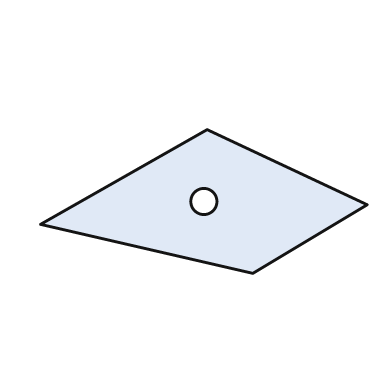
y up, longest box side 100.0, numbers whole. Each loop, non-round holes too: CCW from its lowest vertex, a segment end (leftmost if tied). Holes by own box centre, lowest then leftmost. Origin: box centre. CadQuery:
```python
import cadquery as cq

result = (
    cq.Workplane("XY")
    .moveTo(15.0, -22.0)
    .lineTo(50.0, -1.0)
    .lineTo(1.0, 22.0)
    .lineTo(-50.0, -7.0)
    .close()
    .moveTo(0.0, 0.0)
    .circle(4.0)
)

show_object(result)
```